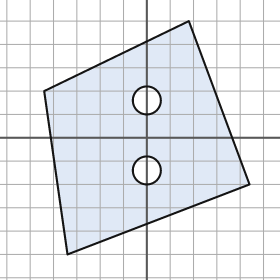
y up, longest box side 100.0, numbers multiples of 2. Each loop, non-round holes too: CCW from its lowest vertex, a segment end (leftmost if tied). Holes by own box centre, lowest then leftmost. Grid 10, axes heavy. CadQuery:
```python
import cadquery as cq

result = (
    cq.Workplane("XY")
    .moveTo(-34.0, -50.0)
    .lineTo(44.0, -20.0)
    .lineTo(18.0, 50.0)
    .lineTo(-44.0, 20.0)
    .close()
    .moveTo(0.0, -14.0)
    .circle(6.0)
    .moveTo(0.0, 16.0)
    .circle(6.0)
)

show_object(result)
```